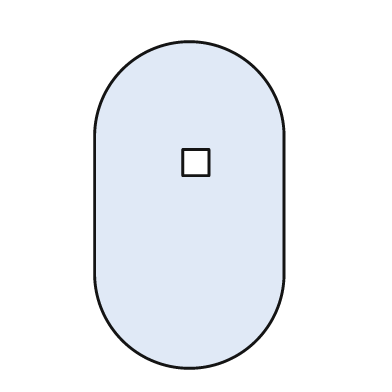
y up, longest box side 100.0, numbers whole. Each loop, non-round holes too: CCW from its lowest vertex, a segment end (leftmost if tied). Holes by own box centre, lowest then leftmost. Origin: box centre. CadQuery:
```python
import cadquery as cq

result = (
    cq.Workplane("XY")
    .moveTo(-29.0, -21.0)
    .threePointArc((0.0, -50.0), (29.0, -21.0))
    .lineTo(29.0, 21.0)
    .threePointArc((0.0, 50.0), (-29.0, 21.0))
    .close()
    .moveTo(-2.0, 9.0)
    .lineTo(6.0, 9.0)
    .lineTo(6.0, 17.0)
    .lineTo(-2.0, 17.0)
    .close()
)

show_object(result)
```